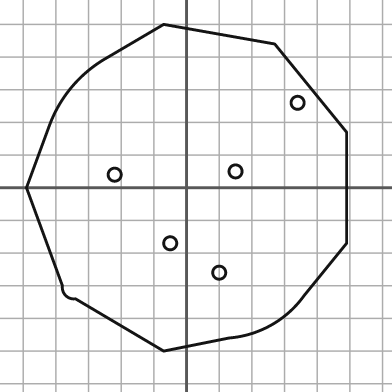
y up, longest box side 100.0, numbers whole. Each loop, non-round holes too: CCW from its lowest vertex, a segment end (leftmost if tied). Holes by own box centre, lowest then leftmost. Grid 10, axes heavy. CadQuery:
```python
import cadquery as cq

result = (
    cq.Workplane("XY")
    .moveTo(-7.0, -50.0)
    .lineTo(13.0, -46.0)
    .threePointArc((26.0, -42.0), (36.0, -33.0))
    .lineTo(49.0, -17.0)
    .lineTo(49.0, 17.0)
    .lineTo(27.0, 44.0)
    .lineTo(-7.0, 50.0)
    .lineTo(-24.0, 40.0)
    .threePointArc((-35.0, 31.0), (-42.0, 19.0))
    .lineTo(-49.0, 0.0)
    .lineTo(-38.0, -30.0)
    .threePointArc((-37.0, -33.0), (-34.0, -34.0))
    .close()
    .moveTo(10.0, -26.0)
    .circle(2.0)
    .moveTo(-5.0, -17.0)
    .circle(2.0)
    .moveTo(-22.0, 4.0)
    .circle(2.0)
    .moveTo(15.0, 5.0)
    .circle(2.0)
    .moveTo(34.0, 26.0)
    .circle(2.0)
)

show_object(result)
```